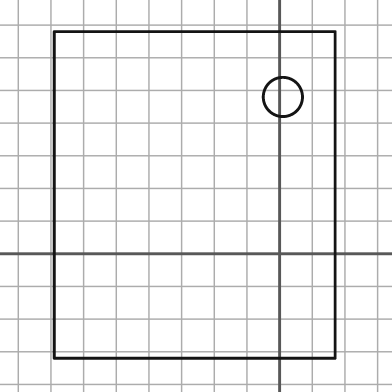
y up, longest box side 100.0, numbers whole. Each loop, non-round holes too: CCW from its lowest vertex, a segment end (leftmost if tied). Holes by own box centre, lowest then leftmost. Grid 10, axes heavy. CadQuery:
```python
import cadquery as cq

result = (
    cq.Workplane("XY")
    .moveTo(-69.0, -32.0)
    .lineTo(17.0, -32.0)
    .lineTo(17.0, 68.0)
    .lineTo(-69.0, 68.0)
    .close()
    .moveTo(1.0, 48.0)
    .circle(6.0)
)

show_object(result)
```